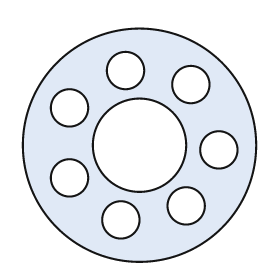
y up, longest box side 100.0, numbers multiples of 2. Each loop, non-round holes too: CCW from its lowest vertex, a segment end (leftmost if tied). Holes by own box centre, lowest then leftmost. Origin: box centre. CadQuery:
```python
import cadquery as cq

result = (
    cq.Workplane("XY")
    .moveTo(0.0, 0.0)
    .circle(50.0)
    .moveTo(-8.0, -32.0)
    .circle(8.0)
    .moveTo(20.0, -26.0)
    .circle(8.0)
    .moveTo(-30.0, -14.0)
    .circle(8.0)
    .moveTo(34.0, -2.0)
    .circle(8.0)
    .moveTo(0.0, 0.0)
    .circle(20.0)
    .moveTo(-30.0, 16.0)
    .circle(8.0)
    .moveTo(22.0, 26.0)
    .circle(8.0)
    .moveTo(-6.0, 32.0)
    .circle(8.0)
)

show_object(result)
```